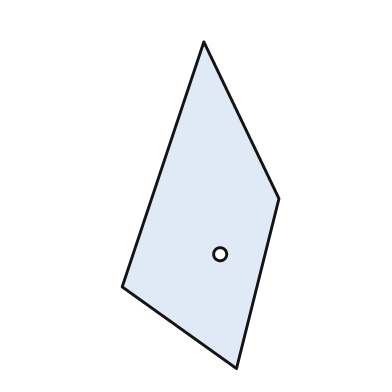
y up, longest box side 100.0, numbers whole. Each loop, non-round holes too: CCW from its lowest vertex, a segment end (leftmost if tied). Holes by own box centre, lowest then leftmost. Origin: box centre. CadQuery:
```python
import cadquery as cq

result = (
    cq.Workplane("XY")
    .moveTo(11.0, -50.0)
    .lineTo(24.0, 2.0)
    .lineTo(1.0, 50.0)
    .lineTo(-24.0, -25.0)
    .close()
    .moveTo(6.0, -15.0)
    .circle(2.0)
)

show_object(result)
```